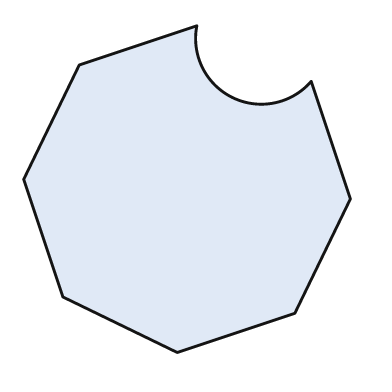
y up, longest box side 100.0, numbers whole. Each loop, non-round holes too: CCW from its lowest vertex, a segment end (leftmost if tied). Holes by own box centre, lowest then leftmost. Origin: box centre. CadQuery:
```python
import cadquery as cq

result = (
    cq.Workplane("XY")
    .moveTo(-3.0, -50.0)
    .lineTo(33.0, -38.0)
    .lineTo(50.0, -3.0)
    .lineTo(38.0, 33.0)
    .threePointArc((14.0, 28.0), (3.0, 50.0))
    .lineTo(-33.0, 38.0)
    .lineTo(-50.0, 3.0)
    .lineTo(-38.0, -33.0)
    .close()
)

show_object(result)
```